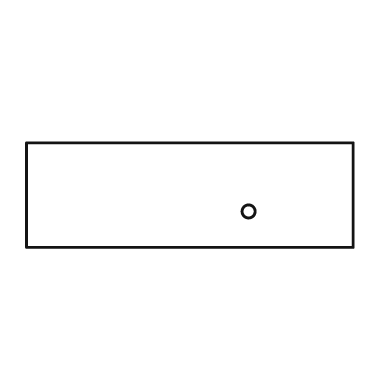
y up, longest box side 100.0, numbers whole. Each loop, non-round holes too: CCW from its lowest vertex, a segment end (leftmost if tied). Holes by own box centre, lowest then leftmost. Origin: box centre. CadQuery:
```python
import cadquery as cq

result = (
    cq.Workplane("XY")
    .moveTo(-50.0, -16.0)
    .lineTo(50.0, -16.0)
    .lineTo(50.0, 16.0)
    .lineTo(-50.0, 16.0)
    .close()
    .moveTo(18.0, -5.0)
    .circle(2.0)
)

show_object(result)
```